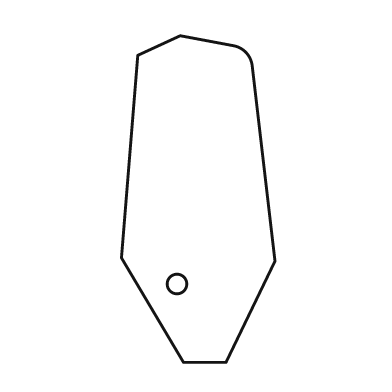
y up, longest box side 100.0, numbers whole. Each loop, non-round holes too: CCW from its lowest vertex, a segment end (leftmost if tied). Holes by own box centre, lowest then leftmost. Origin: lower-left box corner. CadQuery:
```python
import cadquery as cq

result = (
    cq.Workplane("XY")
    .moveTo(19.0, 0.0)
    .lineTo(32.0, 0.0)
    .lineTo(47.0, 31.0)
    .lineTo(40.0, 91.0)
    .threePointArc((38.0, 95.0), (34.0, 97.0))
    .lineTo(18.0, 100.0)
    .lineTo(5.0, 94.0)
    .lineTo(0.0, 32.0)
    .close()
    .moveTo(17.0, 24.0)
    .circle(3.0)
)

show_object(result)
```